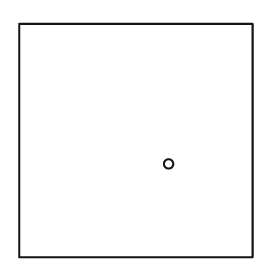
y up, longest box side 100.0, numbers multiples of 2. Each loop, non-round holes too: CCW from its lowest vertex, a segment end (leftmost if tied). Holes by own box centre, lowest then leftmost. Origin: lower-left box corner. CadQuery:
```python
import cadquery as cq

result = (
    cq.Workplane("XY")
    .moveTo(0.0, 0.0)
    .lineTo(100.0, 0.0)
    .lineTo(100.0, 100.0)
    .lineTo(0.0, 100.0)
    .close()
    .moveTo(64.0, 40.0)
    .circle(2.0)
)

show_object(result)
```